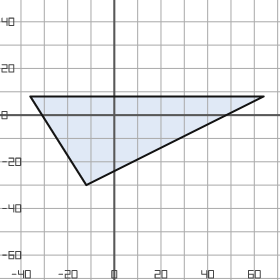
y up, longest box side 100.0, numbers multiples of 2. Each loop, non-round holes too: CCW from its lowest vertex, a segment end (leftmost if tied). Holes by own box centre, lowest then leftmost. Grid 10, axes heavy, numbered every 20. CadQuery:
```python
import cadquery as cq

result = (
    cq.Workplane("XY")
    .moveTo(-12.0, -30.0)
    .lineTo(64.0, 8.0)
    .lineTo(-36.0, 8.0)
    .close()
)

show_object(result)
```